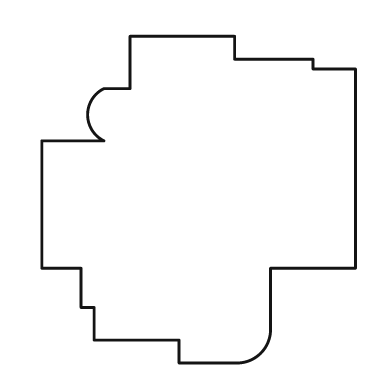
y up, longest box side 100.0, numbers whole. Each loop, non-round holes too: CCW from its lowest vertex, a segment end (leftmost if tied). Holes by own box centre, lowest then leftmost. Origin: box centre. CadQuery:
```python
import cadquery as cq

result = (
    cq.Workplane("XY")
    .moveTo(-6.0, -50.0)
    .lineTo(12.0, -50.0)
    .threePointArc((19.0, -47.0), (22.0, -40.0))
    .lineTo(22.0, -21.0)
    .lineTo(48.0, -21.0)
    .lineTo(48.0, 40.0)
    .lineTo(35.0, 40.0)
    .lineTo(35.0, 43.0)
    .lineTo(11.0, 43.0)
    .lineTo(11.0, 50.0)
    .lineTo(-21.0, 50.0)
    .lineTo(-21.0, 34.0)
    .lineTo(-29.0, 34.0)
    .threePointArc((-34.0, 26.0), (-29.0, 18.0))
    .lineTo(-48.0, 18.0)
    .lineTo(-48.0, -21.0)
    .lineTo(-36.0, -21.0)
    .lineTo(-36.0, -33.0)
    .lineTo(-32.0, -33.0)
    .lineTo(-32.0, -43.0)
    .lineTo(-6.0, -43.0)
    .close()
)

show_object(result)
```